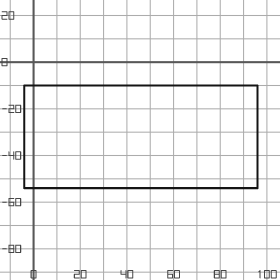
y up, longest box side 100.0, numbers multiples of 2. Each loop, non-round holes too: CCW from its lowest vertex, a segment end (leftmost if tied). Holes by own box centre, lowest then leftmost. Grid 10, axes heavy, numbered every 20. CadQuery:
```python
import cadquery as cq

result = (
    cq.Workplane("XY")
    .moveTo(-4.0, -54.0)
    .lineTo(96.0, -54.0)
    .lineTo(96.0, -10.0)
    .lineTo(-4.0, -10.0)
    .close()
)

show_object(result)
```